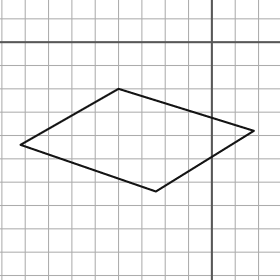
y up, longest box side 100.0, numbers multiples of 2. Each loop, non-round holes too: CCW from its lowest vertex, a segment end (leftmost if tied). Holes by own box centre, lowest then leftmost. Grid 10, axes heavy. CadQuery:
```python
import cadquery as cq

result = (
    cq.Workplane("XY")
    .moveTo(-24.0, -64.0)
    .lineTo(18.0, -38.0)
    .lineTo(-40.0, -20.0)
    .lineTo(-82.0, -44.0)
    .close()
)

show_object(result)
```